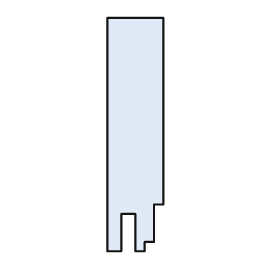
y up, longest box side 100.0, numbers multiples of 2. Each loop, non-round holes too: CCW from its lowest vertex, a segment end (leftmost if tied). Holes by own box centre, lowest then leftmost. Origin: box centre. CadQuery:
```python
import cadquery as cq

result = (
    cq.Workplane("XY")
    .moveTo(-12.0, -50.0)
    .lineTo(-6.0, -50.0)
    .lineTo(-6.0, -34.0)
    .lineTo(0.0, -34.0)
    .lineTo(0.0, -50.0)
    .lineTo(4.0, -50.0)
    .lineTo(4.0, -46.0)
    .lineTo(8.0, -46.0)
    .lineTo(8.0, -30.0)
    .lineTo(12.0, -30.0)
    .lineTo(12.0, 50.0)
    .lineTo(-12.0, 50.0)
    .close()
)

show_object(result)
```